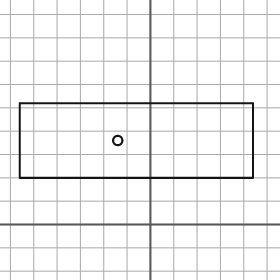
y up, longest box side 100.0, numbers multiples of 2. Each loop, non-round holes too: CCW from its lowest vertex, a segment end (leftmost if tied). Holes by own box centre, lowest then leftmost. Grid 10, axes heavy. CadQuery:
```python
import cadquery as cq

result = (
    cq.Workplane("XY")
    .moveTo(-56.0, 20.0)
    .lineTo(44.0, 20.0)
    .lineTo(44.0, 52.0)
    .lineTo(-56.0, 52.0)
    .close()
    .moveTo(-14.0, 36.0)
    .circle(2.0)
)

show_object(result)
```